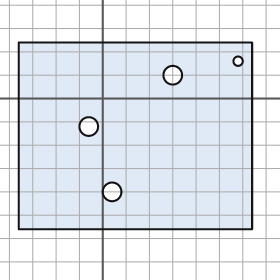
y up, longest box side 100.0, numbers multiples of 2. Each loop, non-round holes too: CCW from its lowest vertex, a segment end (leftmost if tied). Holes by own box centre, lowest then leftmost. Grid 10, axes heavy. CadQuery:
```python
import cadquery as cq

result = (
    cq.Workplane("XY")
    .moveTo(-36.0, -56.0)
    .lineTo(64.0, -56.0)
    .lineTo(64.0, 24.0)
    .lineTo(-36.0, 24.0)
    .close()
    .moveTo(4.0, -40.0)
    .circle(4.0)
    .moveTo(-6.0, -12.0)
    .circle(4.0)
    .moveTo(30.0, 10.0)
    .circle(4.0)
    .moveTo(58.0, 16.0)
    .circle(2.0)
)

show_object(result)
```